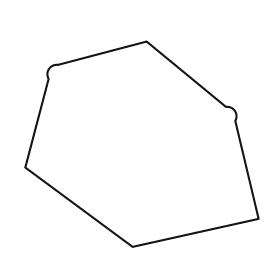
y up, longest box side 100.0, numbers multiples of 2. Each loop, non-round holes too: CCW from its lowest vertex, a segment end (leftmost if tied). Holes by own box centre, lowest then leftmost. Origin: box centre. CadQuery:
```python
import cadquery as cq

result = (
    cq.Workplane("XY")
    .moveTo(-4.0, -44.0)
    .lineTo(50.0, -32.0)
    .lineTo(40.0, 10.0)
    .threePointArc((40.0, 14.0), (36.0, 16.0))
    .lineTo(2.0, 44.0)
    .lineTo(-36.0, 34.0)
    .threePointArc((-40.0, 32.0), (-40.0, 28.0))
    .lineTo(-50.0, -10.0)
    .close()
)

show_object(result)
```